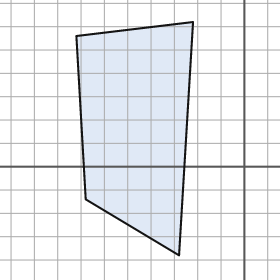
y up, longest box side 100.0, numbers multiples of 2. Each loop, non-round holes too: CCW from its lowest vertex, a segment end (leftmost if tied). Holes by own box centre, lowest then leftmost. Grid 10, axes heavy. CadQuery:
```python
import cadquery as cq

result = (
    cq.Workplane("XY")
    .moveTo(-28.0, -38.0)
    .lineTo(-22.0, 62.0)
    .lineTo(-72.0, 56.0)
    .lineTo(-68.0, -14.0)
    .close()
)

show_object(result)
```